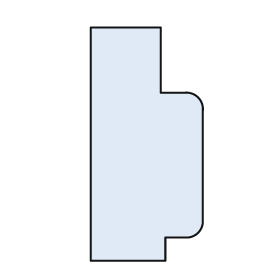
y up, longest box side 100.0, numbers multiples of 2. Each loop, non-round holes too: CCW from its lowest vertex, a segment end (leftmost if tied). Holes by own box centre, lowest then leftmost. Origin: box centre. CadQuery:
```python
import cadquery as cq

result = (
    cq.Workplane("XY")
    .moveTo(-24.0, -50.0)
    .lineTo(8.0, -50.0)
    .lineTo(8.0, -40.0)
    .lineTo(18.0, -40.0)
    .threePointArc((22.0, -38.0), (24.0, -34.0))
    .lineTo(24.0, 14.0)
    .threePointArc((22.0, 20.0), (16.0, 22.0))
    .lineTo(6.0, 22.0)
    .lineTo(6.0, 50.0)
    .lineTo(-24.0, 50.0)
    .close()
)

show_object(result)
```